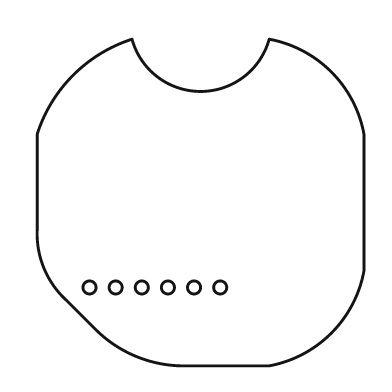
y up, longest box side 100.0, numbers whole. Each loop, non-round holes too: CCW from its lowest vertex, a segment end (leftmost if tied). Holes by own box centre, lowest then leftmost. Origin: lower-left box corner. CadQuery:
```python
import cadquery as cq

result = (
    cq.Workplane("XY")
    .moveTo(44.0, 0.0)
    .lineTo(71.0, 0.0)
    .threePointArc((90.0, 10.0), (100.0, 29.0))
    .lineTo(100.0, 71.0)
    .threePointArc((90.0, 90.0), (71.0, 100.0))
    .threePointArc((50.0, 84.0), (29.0, 100.0))
    .threePointArc((11.0, 89.0), (0.0, 71.0))
    .lineTo(0.0, 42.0)
    .threePointArc((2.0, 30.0), (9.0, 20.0))
    .lineTo(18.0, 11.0)
    .threePointArc((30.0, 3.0), (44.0, 0.0))
    .close()
    .moveTo(16.0, 24.0)
    .circle(2.0)
    .moveTo(24.0, 24.0)
    .circle(2.0)
    .moveTo(32.0, 24.0)
    .circle(2.0)
    .moveTo(40.0, 24.0)
    .circle(2.0)
    .moveTo(48.0, 24.0)
    .circle(2.0)
    .moveTo(56.0, 24.0)
    .circle(2.0)
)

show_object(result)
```